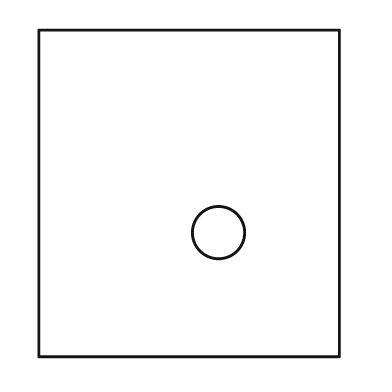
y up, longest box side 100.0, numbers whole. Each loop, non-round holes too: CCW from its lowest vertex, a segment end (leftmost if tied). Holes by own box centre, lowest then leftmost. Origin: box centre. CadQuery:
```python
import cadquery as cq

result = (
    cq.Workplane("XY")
    .moveTo(-46.0, -50.0)
    .lineTo(46.0, -50.0)
    .lineTo(46.0, 50.0)
    .lineTo(-46.0, 50.0)
    .close()
    .moveTo(9.0, -12.0)
    .circle(8.0)
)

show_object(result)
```